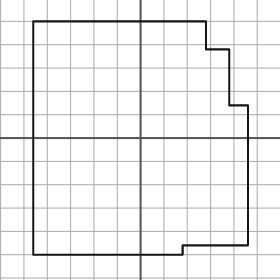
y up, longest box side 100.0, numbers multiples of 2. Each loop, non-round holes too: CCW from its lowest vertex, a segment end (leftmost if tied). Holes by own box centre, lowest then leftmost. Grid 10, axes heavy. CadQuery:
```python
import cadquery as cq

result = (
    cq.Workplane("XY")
    .moveTo(-46.0, -50.0)
    .lineTo(18.0, -50.0)
    .lineTo(18.0, -46.0)
    .lineTo(46.0, -46.0)
    .lineTo(46.0, 14.0)
    .lineTo(38.0, 14.0)
    .lineTo(38.0, 38.0)
    .lineTo(28.0, 38.0)
    .lineTo(28.0, 50.0)
    .lineTo(-46.0, 50.0)
    .close()
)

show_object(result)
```